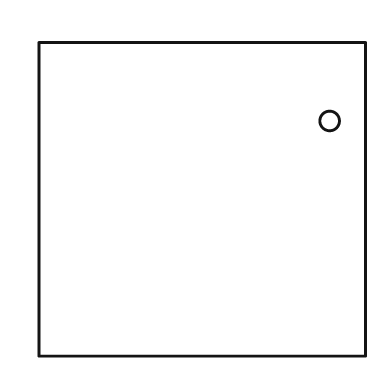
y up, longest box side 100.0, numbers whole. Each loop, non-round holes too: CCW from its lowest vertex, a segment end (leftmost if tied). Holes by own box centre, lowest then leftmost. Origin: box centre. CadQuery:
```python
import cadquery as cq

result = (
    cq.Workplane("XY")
    .moveTo(-50.0, -48.0)
    .lineTo(50.0, -48.0)
    .lineTo(50.0, 48.0)
    .lineTo(-50.0, 48.0)
    .close()
    .moveTo(39.0, 24.0)
    .circle(3.0)
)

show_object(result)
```